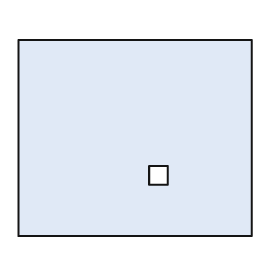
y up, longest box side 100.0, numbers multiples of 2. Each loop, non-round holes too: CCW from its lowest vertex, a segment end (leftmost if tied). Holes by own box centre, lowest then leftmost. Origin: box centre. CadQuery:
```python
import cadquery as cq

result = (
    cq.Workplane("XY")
    .moveTo(-50.0, -42.0)
    .lineTo(50.0, -42.0)
    .lineTo(50.0, 42.0)
    .lineTo(-50.0, 42.0)
    .close()
    .moveTo(6.0, -20.0)
    .lineTo(14.0, -20.0)
    .lineTo(14.0, -12.0)
    .lineTo(6.0, -12.0)
    .close()
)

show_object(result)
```